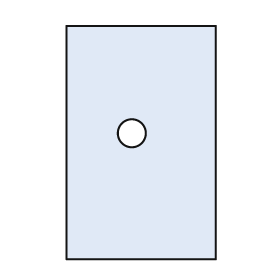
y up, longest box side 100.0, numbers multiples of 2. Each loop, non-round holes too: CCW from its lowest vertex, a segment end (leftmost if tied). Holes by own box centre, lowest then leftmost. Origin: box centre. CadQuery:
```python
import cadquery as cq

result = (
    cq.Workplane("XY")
    .moveTo(-32.0, -50.0)
    .lineTo(32.0, -50.0)
    .lineTo(32.0, 50.0)
    .lineTo(-32.0, 50.0)
    .close()
    .moveTo(-4.0, 4.0)
    .circle(6.0)
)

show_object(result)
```